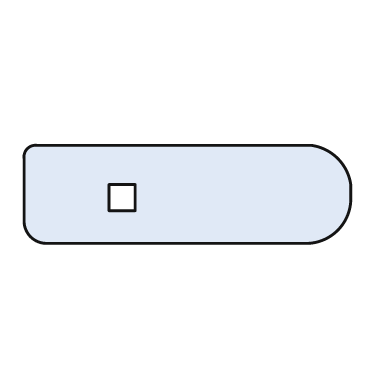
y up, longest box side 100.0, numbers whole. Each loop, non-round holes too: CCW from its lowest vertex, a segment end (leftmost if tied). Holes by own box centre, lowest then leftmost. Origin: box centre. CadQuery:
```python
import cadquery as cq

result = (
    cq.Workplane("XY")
    .moveTo(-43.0, -15.0)
    .lineTo(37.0, -15.0)
    .threePointArc((46.0, -11.0), (50.0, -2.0))
    .lineTo(50.0, 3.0)
    .threePointArc((46.0, 11.0), (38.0, 15.0))
    .lineTo(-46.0, 15.0)
    .threePointArc((-49.0, 14.0), (-50.0, 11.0))
    .lineTo(-50.0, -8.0)
    .threePointArc((-48.0, -13.0), (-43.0, -15.0))
    .close()
    .moveTo(-24.0, -5.0)
    .lineTo(-16.0, -5.0)
    .lineTo(-16.0, 3.0)
    .lineTo(-24.0, 3.0)
    .close()
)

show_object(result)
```